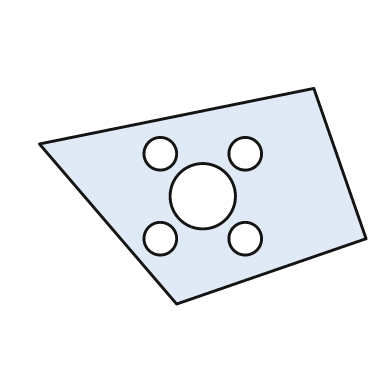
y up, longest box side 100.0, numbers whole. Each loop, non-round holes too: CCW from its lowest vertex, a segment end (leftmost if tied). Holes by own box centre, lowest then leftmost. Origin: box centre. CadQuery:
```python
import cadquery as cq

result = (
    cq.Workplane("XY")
    .moveTo(-8.0, -33.0)
    .lineTo(50.0, -13.0)
    .lineTo(34.0, 33.0)
    .lineTo(-50.0, 16.0)
    .close()
    .moveTo(-13.0, -13.0)
    .circle(5.0)
    .moveTo(13.0, -13.0)
    .circle(5.0)
    .moveTo(0.0, 0.0)
    .circle(10.0)
    .moveTo(-13.0, 13.0)
    .circle(5.0)
    .moveTo(13.0, 13.0)
    .circle(5.0)
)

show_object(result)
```